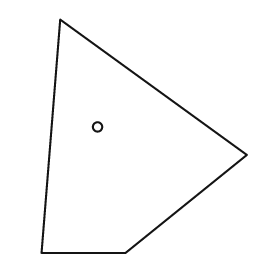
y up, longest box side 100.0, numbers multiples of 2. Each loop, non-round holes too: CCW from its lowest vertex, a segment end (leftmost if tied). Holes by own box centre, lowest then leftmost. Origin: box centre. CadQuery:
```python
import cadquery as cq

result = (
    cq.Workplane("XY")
    .moveTo(-44.0, -50.0)
    .lineTo(-8.0, -50.0)
    .lineTo(44.0, -8.0)
    .lineTo(-36.0, 50.0)
    .close()
    .moveTo(-20.0, 4.0)
    .circle(2.0)
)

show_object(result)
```